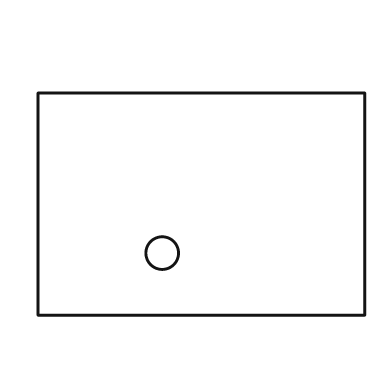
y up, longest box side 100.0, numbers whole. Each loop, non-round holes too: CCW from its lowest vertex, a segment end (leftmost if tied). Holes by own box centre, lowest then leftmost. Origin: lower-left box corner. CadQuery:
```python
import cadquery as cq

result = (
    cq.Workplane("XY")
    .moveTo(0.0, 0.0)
    .lineTo(100.0, 0.0)
    .lineTo(100.0, 68.0)
    .lineTo(0.0, 68.0)
    .close()
    .moveTo(38.0, 19.0)
    .circle(5.0)
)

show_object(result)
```